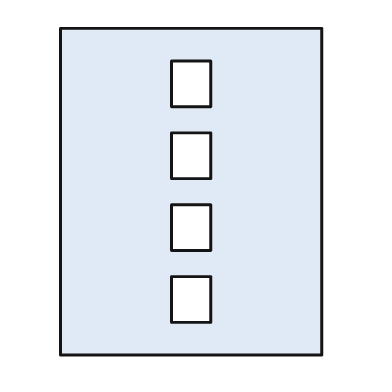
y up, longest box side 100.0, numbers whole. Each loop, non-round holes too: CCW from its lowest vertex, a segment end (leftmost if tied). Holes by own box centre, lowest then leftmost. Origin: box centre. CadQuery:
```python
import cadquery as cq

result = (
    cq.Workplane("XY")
    .moveTo(-40.0, -50.0)
    .lineTo(40.0, -50.0)
    .lineTo(40.0, 50.0)
    .lineTo(-40.0, 50.0)
    .close()
    .moveTo(-6.0, -40.0)
    .lineTo(6.0, -40.0)
    .lineTo(6.0, -26.0)
    .lineTo(-6.0, -26.0)
    .close()
    .moveTo(-6.0, -18.0)
    .lineTo(6.0, -18.0)
    .lineTo(6.0, -4.0)
    .lineTo(-6.0, -4.0)
    .close()
    .moveTo(-6.0, 4.0)
    .lineTo(6.0, 4.0)
    .lineTo(6.0, 18.0)
    .lineTo(-6.0, 18.0)
    .close()
    .moveTo(-6.0, 26.0)
    .lineTo(6.0, 26.0)
    .lineTo(6.0, 40.0)
    .lineTo(-6.0, 40.0)
    .close()
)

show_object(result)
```